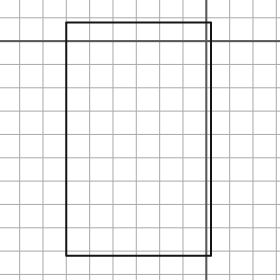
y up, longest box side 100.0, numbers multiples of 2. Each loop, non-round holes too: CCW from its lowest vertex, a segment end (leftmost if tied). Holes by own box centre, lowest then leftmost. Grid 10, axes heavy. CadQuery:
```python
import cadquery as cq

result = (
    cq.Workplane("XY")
    .moveTo(-60.0, -92.0)
    .lineTo(2.0, -92.0)
    .lineTo(2.0, 8.0)
    .lineTo(-60.0, 8.0)
    .close()
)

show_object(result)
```